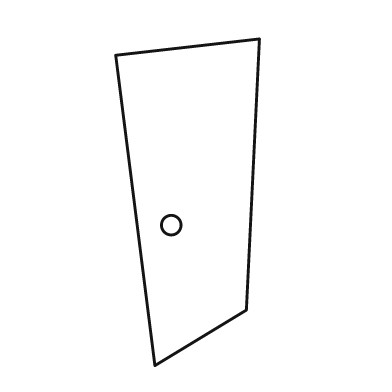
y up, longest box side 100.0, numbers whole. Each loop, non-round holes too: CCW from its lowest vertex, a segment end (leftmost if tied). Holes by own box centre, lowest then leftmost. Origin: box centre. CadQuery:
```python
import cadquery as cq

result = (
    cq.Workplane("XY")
    .moveTo(-10.0, -50.0)
    .lineTo(18.0, -33.0)
    .lineTo(22.0, 50.0)
    .lineTo(-22.0, 45.0)
    .close()
    .moveTo(-5.0, -7.0)
    .circle(3.0)
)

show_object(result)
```